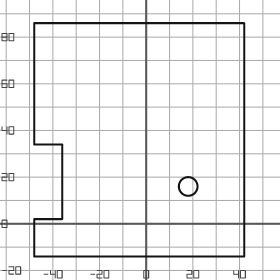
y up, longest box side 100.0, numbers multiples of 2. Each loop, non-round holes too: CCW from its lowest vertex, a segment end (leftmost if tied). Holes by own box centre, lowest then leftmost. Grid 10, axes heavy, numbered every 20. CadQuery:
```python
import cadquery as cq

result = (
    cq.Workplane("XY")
    .moveTo(-48.0, -14.0)
    .lineTo(42.0, -14.0)
    .lineTo(42.0, 86.0)
    .lineTo(-48.0, 86.0)
    .lineTo(-48.0, 34.0)
    .lineTo(-36.0, 34.0)
    .lineTo(-36.0, 2.0)
    .lineTo(-48.0, 2.0)
    .close()
    .moveTo(18.0, 16.0)
    .circle(4.0)
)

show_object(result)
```